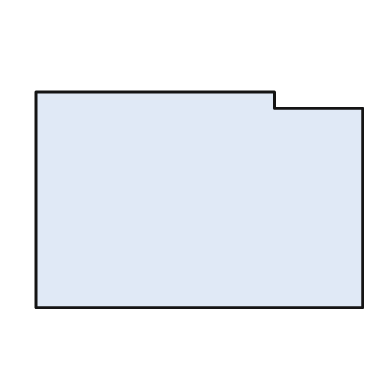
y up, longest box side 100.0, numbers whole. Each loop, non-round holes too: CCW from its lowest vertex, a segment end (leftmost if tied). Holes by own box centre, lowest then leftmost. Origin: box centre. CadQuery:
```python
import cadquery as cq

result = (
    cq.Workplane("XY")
    .moveTo(-50.0, -33.0)
    .lineTo(50.0, -33.0)
    .lineTo(50.0, 28.0)
    .lineTo(23.0, 28.0)
    .lineTo(23.0, 33.0)
    .lineTo(-50.0, 33.0)
    .close()
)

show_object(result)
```